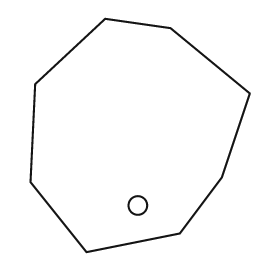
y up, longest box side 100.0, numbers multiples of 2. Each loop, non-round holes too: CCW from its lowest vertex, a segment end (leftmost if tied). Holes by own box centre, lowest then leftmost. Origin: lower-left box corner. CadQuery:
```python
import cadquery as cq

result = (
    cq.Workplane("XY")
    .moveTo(24.0, 0.0)
    .lineTo(64.0, 8.0)
    .lineTo(82.0, 32.0)
    .lineTo(94.0, 68.0)
    .lineTo(60.0, 96.0)
    .lineTo(32.0, 100.0)
    .lineTo(2.0, 72.0)
    .lineTo(0.0, 30.0)
    .close()
    .moveTo(46.0, 20.0)
    .circle(4.0)
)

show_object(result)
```